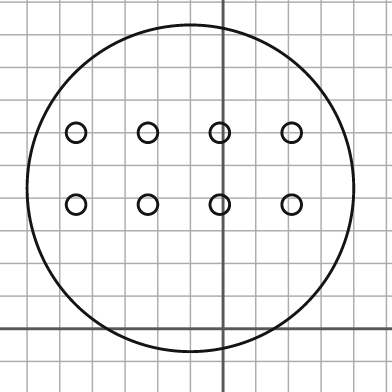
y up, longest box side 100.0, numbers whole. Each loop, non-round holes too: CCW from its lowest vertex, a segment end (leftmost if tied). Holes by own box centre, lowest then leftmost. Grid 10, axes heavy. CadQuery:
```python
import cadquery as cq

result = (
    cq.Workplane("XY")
    .moveTo(-10.0, 43.0)
    .circle(50.0)
    .moveTo(-45.0, 38.0)
    .circle(3.0)
    .moveTo(-23.0, 38.0)
    .circle(3.0)
    .moveTo(-1.0, 38.0)
    .circle(3.0)
    .moveTo(21.0, 38.0)
    .circle(3.0)
    .moveTo(-45.0, 60.0)
    .circle(3.0)
    .moveTo(-23.0, 60.0)
    .circle(3.0)
    .moveTo(-1.0, 60.0)
    .circle(3.0)
    .moveTo(21.0, 60.0)
    .circle(3.0)
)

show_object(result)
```